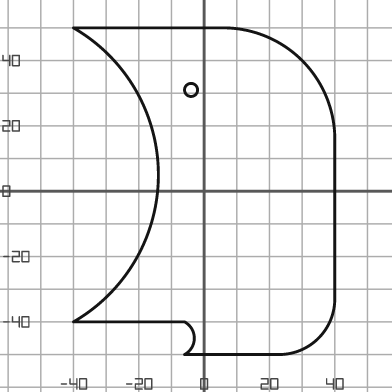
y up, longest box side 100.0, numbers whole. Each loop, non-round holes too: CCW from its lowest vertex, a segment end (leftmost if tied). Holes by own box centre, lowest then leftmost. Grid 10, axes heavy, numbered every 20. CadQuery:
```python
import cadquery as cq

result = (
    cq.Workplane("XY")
    .moveTo(-6.0, -50.0)
    .lineTo(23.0, -50.0)
    .threePointArc((35.0, -45.0), (40.0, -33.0))
    .lineTo(40.0, 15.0)
    .threePointArc((30.0, 40.0), (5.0, 50.0))
    .lineTo(-40.0, 50.0)
    .threePointArc((-14.0, 5.0), (-40.0, -40.0))
    .lineTo(-6.0, -40.0)
    .threePointArc((-3.0, -45.0), (-6.0, -50.0))
    .close()
    .moveTo(-4.0, 31.0)
    .circle(2.0)
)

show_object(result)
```